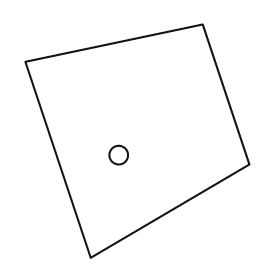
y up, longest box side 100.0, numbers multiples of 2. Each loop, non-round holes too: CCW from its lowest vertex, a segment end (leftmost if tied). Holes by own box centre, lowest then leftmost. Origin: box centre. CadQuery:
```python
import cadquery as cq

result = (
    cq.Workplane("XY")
    .moveTo(-20.0, -50.0)
    .lineTo(48.0, -10.0)
    .lineTo(28.0, 50.0)
    .lineTo(-48.0, 34.0)
    .close()
    .moveTo(-8.0, -6.0)
    .circle(4.0)
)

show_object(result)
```